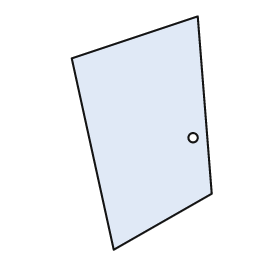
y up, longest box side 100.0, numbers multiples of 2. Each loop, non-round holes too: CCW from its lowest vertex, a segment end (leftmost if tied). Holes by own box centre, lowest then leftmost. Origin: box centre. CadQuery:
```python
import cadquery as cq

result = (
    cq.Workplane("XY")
    .moveTo(-12.0, -50.0)
    .lineTo(30.0, -26.0)
    .lineTo(24.0, 50.0)
    .lineTo(-30.0, 32.0)
    .close()
    .moveTo(22.0, -2.0)
    .circle(2.0)
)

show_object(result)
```